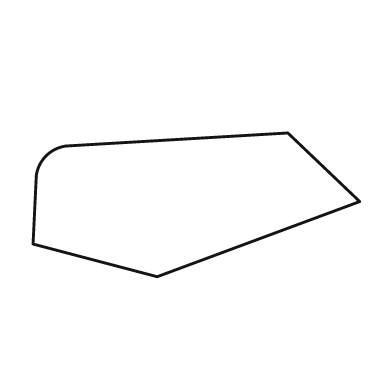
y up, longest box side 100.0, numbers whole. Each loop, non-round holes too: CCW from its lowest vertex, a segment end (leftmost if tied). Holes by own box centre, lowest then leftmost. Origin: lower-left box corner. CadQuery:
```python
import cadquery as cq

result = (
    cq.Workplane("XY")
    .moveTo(38.0, 0.0)
    .lineTo(100.0, 23.0)
    .lineTo(78.0, 44.0)
    .lineTo(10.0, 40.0)
    .threePointArc((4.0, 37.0), (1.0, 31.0))
    .lineTo(0.0, 10.0)
    .close()
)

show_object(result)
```